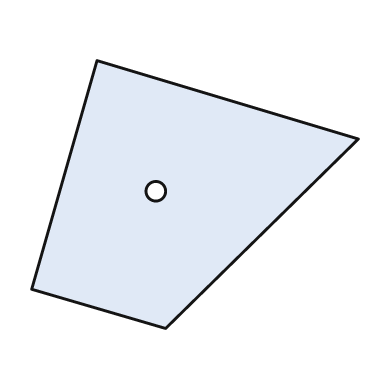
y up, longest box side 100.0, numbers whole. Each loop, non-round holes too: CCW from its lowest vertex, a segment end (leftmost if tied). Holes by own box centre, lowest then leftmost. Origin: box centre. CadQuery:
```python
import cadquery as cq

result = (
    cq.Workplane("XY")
    .moveTo(-9.0, -41.0)
    .lineTo(50.0, 17.0)
    .lineTo(-30.0, 41.0)
    .lineTo(-50.0, -29.0)
    .close()
    .moveTo(-12.0, 1.0)
    .circle(3.0)
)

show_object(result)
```